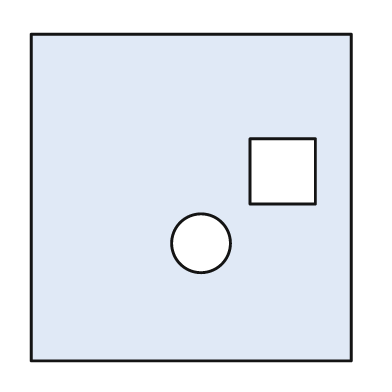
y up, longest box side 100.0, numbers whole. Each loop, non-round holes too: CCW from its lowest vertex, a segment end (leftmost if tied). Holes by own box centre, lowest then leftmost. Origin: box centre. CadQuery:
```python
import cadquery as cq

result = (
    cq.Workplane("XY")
    .moveTo(-49.0, -50.0)
    .lineTo(49.0, -50.0)
    .lineTo(49.0, 50.0)
    .lineTo(-49.0, 50.0)
    .close()
    .moveTo(3.0, -14.0)
    .circle(9.0)
    .moveTo(18.0, -2.0)
    .lineTo(38.0, -2.0)
    .lineTo(38.0, 18.0)
    .lineTo(18.0, 18.0)
    .close()
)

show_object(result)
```